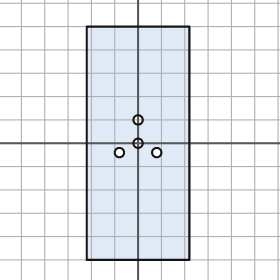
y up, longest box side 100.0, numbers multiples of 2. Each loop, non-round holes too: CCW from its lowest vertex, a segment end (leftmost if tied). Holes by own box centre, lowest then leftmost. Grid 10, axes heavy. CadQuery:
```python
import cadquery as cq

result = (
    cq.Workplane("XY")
    .moveTo(-22.0, -50.0)
    .lineTo(22.0, -50.0)
    .lineTo(22.0, 50.0)
    .lineTo(-22.0, 50.0)
    .close()
    .moveTo(-8.0, -4.0)
    .circle(2.0)
    .moveTo(8.0, -4.0)
    .circle(2.0)
    .moveTo(0.0, 0.0)
    .circle(2.0)
    .moveTo(0.0, 10.0)
    .circle(2.0)
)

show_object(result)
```